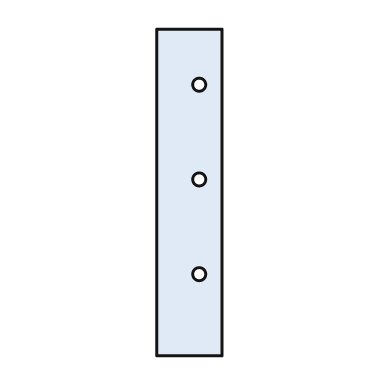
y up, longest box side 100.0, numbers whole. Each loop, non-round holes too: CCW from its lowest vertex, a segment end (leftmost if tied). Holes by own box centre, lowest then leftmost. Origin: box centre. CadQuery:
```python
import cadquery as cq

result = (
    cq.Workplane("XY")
    .moveTo(-10.0, -50.0)
    .lineTo(10.0, -50.0)
    .lineTo(10.0, 50.0)
    .lineTo(-10.0, 50.0)
    .close()
    .moveTo(3.0, -25.0)
    .circle(2.0)
    .moveTo(3.0, 4.0)
    .circle(2.0)
    .moveTo(3.0, 33.0)
    .circle(2.0)
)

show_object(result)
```